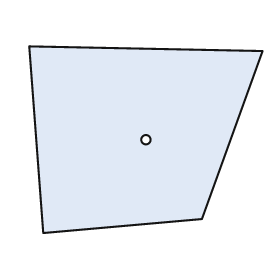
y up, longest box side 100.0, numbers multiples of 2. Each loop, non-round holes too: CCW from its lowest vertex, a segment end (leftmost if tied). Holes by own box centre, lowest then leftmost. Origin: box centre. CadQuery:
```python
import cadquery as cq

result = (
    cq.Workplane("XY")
    .moveTo(-44.0, -40.0)
    .lineTo(24.0, -34.0)
    .lineTo(50.0, 38.0)
    .lineTo(-50.0, 40.0)
    .close()
    .moveTo(0.0, 0.0)
    .circle(2.0)
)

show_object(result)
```